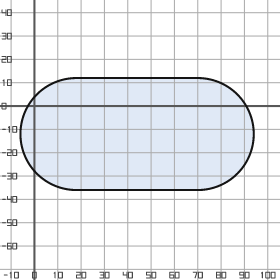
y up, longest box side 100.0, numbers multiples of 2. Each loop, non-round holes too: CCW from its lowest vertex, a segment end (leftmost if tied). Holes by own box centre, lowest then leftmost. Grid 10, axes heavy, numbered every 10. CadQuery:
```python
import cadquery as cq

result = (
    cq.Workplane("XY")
    .moveTo(18.0, -36.0)
    .lineTo(70.0, -36.0)
    .threePointArc((94.0, -12.0), (70.0, 12.0))
    .lineTo(18.0, 12.0)
    .threePointArc((-6.0, -12.0), (18.0, -36.0))
    .close()
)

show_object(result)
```